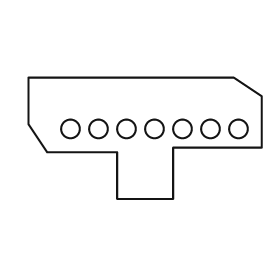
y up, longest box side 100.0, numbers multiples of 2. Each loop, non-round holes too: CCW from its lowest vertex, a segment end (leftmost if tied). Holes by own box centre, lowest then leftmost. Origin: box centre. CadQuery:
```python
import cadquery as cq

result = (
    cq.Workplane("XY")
    .moveTo(-12.0, -26.0)
    .lineTo(12.0, -26.0)
    .lineTo(12.0, -4.0)
    .lineTo(50.0, -4.0)
    .lineTo(50.0, 18.0)
    .lineTo(38.0, 26.0)
    .lineTo(-50.0, 26.0)
    .lineTo(-50.0, 6.0)
    .lineTo(-42.0, -6.0)
    .lineTo(-12.0, -6.0)
    .close()
    .moveTo(-32.0, 4.0)
    .circle(4.0)
    .moveTo(-20.0, 4.0)
    .circle(4.0)
    .moveTo(-8.0, 4.0)
    .circle(4.0)
    .moveTo(4.0, 4.0)
    .circle(4.0)
    .moveTo(16.0, 4.0)
    .circle(4.0)
    .moveTo(28.0, 4.0)
    .circle(4.0)
    .moveTo(40.0, 4.0)
    .circle(4.0)
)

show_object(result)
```